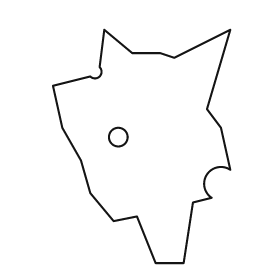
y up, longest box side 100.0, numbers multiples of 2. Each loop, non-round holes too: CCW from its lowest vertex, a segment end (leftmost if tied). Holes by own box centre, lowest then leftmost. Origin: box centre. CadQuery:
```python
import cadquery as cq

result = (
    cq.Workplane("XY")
    .moveTo(6.0, -50.0)
    .lineTo(18.0, -50.0)
    .lineTo(22.0, -24.0)
    .lineTo(30.0, -22.0)
    .threePointArc((28.0, -12.0), (38.0, -10.0))
    .lineTo(34.0, 8.0)
    .lineTo(28.0, 16.0)
    .lineTo(38.0, 50.0)
    .lineTo(14.0, 38.0)
    .lineTo(8.0, 40.0)
    .lineTo(-4.0, 40.0)
    .lineTo(-16.0, 50.0)
    .lineTo(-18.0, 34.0)
    .threePointArc((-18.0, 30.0), (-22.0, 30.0))
    .lineTo(-38.0, 26.0)
    .lineTo(-34.0, 8.0)
    .lineTo(-26.0, -6.0)
    .lineTo(-22.0, -20.0)
    .lineTo(-12.0, -32.0)
    .lineTo(-2.0, -30.0)
    .close()
    .moveTo(-10.0, 4.0)
    .circle(4.0)
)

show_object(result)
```